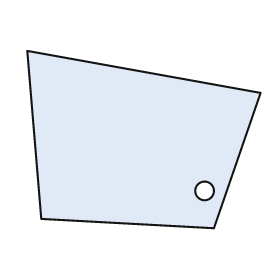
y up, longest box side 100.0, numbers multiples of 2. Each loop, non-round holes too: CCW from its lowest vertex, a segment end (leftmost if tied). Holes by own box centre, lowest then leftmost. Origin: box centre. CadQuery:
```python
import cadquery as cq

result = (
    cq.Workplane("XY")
    .moveTo(30.0, -38.0)
    .lineTo(50.0, 20.0)
    .lineTo(-50.0, 38.0)
    .lineTo(-44.0, -34.0)
    .close()
    .moveTo(26.0, -22.0)
    .circle(4.0)
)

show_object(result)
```